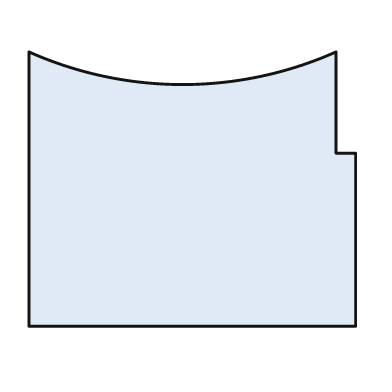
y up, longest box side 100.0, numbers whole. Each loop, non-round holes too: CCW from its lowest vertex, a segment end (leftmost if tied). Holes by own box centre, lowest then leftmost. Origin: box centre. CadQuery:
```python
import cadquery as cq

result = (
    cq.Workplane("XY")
    .moveTo(-50.0, -42.0)
    .lineTo(50.0, -42.0)
    .lineTo(50.0, 11.0)
    .lineTo(44.0, 11.0)
    .lineTo(44.0, 42.0)
    .threePointArc((-3.0, 32.0), (-50.0, 42.0))
    .close()
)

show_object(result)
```